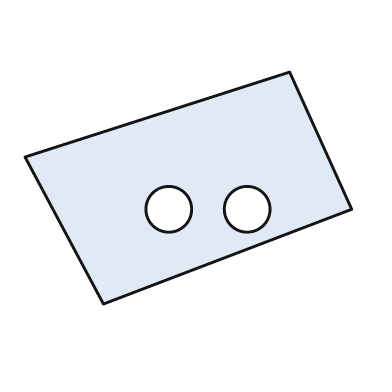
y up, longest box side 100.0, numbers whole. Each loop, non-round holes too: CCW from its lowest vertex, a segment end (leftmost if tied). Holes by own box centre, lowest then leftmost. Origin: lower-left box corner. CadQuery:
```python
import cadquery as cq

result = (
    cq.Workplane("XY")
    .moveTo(24.0, 0.0)
    .lineTo(100.0, 29.0)
    .lineTo(81.0, 71.0)
    .lineTo(0.0, 45.0)
    .close()
    .moveTo(44.0, 29.0)
    .circle(7.0)
    .moveTo(68.0, 29.0)
    .circle(7.0)
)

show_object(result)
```